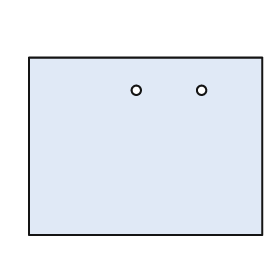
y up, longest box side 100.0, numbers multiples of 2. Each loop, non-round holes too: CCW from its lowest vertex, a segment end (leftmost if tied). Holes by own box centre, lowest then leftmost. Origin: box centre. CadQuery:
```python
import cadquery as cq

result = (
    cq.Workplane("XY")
    .moveTo(-50.0, -38.0)
    .lineTo(50.0, -38.0)
    .lineTo(50.0, 38.0)
    .lineTo(-50.0, 38.0)
    .close()
    .moveTo(-4.0, 24.0)
    .circle(2.0)
    .moveTo(24.0, 24.0)
    .circle(2.0)
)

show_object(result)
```